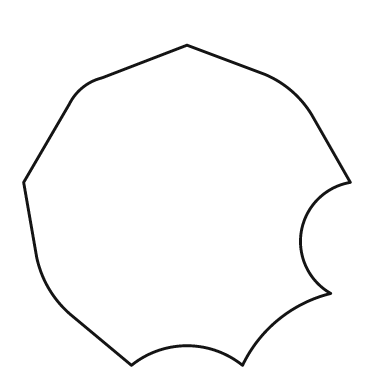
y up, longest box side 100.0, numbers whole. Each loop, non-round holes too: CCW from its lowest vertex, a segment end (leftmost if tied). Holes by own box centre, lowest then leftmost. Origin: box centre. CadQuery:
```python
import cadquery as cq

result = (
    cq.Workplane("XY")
    .moveTo(-17.0, -49.0)
    .threePointArc((0.0, -43.0), (17.0, -49.0))
    .threePointArc((28.0, -35.0), (44.0, -27.0))
    .threePointArc((35.0, -8.0), (50.0, 7.0))
    .lineTo(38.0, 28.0)
    .threePointArc((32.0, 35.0), (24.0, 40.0))
    .lineTo(0.0, 49.0)
    .lineTo(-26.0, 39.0)
    .threePointArc((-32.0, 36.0), (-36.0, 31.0))
    .lineTo(-50.0, 7.0)
    .lineTo(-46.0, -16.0)
    .threePointArc((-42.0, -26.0), (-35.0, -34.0))
    .close()
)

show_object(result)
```